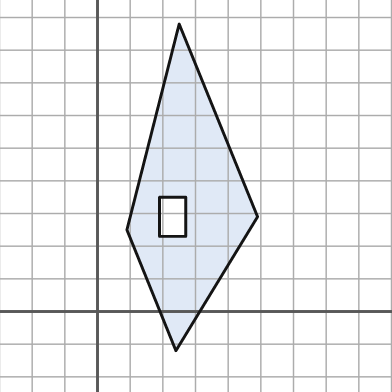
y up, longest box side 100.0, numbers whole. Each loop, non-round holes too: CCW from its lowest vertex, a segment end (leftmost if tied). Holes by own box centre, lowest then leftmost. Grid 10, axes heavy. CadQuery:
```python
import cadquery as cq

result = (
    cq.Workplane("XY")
    .moveTo(24.0, -12.0)
    .lineTo(49.0, 29.0)
    .lineTo(25.0, 88.0)
    .lineTo(9.0, 25.0)
    .close()
    .moveTo(19.0, 23.0)
    .lineTo(27.0, 23.0)
    .lineTo(27.0, 35.0)
    .lineTo(19.0, 35.0)
    .close()
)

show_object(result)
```